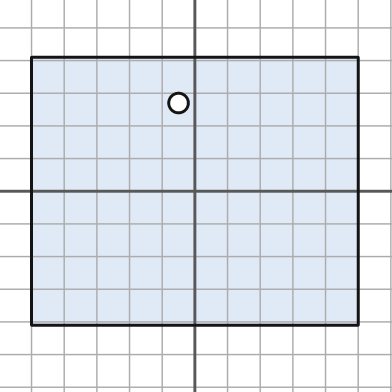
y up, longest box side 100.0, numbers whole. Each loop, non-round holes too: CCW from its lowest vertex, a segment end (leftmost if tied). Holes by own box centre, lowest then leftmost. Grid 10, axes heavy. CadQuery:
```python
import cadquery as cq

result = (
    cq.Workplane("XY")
    .moveTo(-50.0, -41.0)
    .lineTo(50.0, -41.0)
    .lineTo(50.0, 41.0)
    .lineTo(-50.0, 41.0)
    .close()
    .moveTo(-5.0, 27.0)
    .circle(3.0)
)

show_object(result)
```